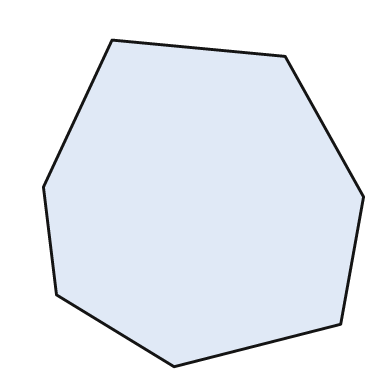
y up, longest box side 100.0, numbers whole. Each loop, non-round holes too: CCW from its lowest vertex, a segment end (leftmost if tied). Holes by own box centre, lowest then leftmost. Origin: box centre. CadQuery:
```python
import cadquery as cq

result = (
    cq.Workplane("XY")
    .moveTo(-9.0, -50.0)
    .lineTo(42.0, -37.0)
    .lineTo(49.0, 2.0)
    .lineTo(25.0, 45.0)
    .lineTo(-28.0, 50.0)
    .lineTo(-49.0, 5.0)
    .lineTo(-45.0, -28.0)
    .close()
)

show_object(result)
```